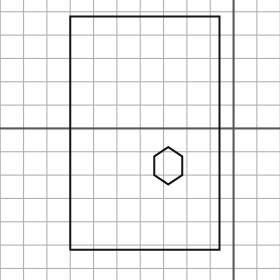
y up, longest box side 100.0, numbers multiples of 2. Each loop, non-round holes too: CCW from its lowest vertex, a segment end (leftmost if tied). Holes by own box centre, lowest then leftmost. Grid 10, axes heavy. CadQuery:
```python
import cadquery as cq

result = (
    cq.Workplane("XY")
    .moveTo(-70.0, -52.0)
    .lineTo(-6.0, -52.0)
    .lineTo(-6.0, 48.0)
    .lineTo(-70.0, 48.0)
    .close()
    .moveTo(-28.0, -24.0)
    .lineTo(-22.0, -20.0)
    .lineTo(-22.0, -12.0)
    .lineTo(-28.0, -8.0)
    .lineTo(-34.0, -12.0)
    .lineTo(-34.0, -20.0)
    .close()
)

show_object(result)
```